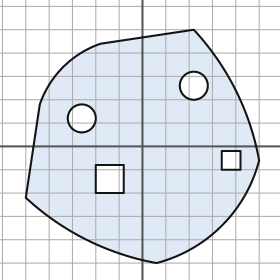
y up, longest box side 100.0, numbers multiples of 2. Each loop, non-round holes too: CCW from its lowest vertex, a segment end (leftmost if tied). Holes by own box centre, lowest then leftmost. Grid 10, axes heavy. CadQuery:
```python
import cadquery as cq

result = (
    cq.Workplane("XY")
    .moveTo(6.0, -50.0)
    .threePointArc((34.0, -34.0), (50.0, -6.0))
    .threePointArc((40.0, 24.0), (22.0, 50.0))
    .lineTo(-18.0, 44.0)
    .threePointArc((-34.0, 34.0), (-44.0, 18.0))
    .lineTo(-50.0, -22.0)
    .threePointArc((-24.0, -40.0), (6.0, -50.0))
    .close()
    .moveTo(-20.0, -20.0)
    .lineTo(-8.0, -20.0)
    .lineTo(-8.0, -8.0)
    .lineTo(-20.0, -8.0)
    .close()
    .moveTo(34.0, -10.0)
    .lineTo(42.0, -10.0)
    .lineTo(42.0, -2.0)
    .lineTo(34.0, -2.0)
    .close()
    .moveTo(-26.0, 12.0)
    .circle(6.0)
    .moveTo(22.0, 26.0)
    .circle(6.0)
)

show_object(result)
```